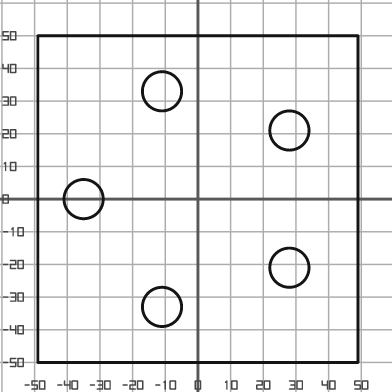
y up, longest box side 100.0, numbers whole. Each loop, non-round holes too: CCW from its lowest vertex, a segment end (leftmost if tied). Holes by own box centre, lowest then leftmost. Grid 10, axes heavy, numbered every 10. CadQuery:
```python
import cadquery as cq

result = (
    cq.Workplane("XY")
    .moveTo(-49.0, -50.0)
    .lineTo(49.0, -50.0)
    .lineTo(49.0, 50.0)
    .lineTo(-49.0, 50.0)
    .close()
    .moveTo(-11.0, -33.0)
    .circle(6.0)
    .moveTo(28.0, -21.0)
    .circle(6.0)
    .moveTo(-35.0, 0.0)
    .circle(6.0)
    .moveTo(28.0, 21.0)
    .circle(6.0)
    .moveTo(-11.0, 33.0)
    .circle(6.0)
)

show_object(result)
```